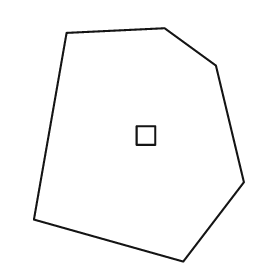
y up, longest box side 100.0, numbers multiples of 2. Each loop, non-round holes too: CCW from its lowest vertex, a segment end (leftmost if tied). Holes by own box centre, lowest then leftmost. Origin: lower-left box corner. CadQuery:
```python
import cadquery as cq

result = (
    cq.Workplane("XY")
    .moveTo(64.0, 0.0)
    .lineTo(90.0, 34.0)
    .lineTo(78.0, 84.0)
    .lineTo(56.0, 100.0)
    .lineTo(14.0, 98.0)
    .lineTo(0.0, 18.0)
    .close()
    .moveTo(44.0, 50.0)
    .lineTo(52.0, 50.0)
    .lineTo(52.0, 58.0)
    .lineTo(44.0, 58.0)
    .close()
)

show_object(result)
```